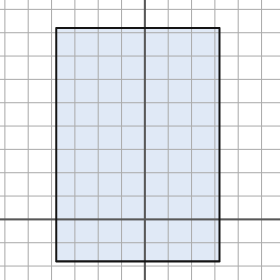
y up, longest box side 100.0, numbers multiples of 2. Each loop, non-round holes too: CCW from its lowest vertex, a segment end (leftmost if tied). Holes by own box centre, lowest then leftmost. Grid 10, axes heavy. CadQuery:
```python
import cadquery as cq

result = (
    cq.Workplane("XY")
    .moveTo(-38.0, -18.0)
    .lineTo(32.0, -18.0)
    .lineTo(32.0, 82.0)
    .lineTo(-38.0, 82.0)
    .close()
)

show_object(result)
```